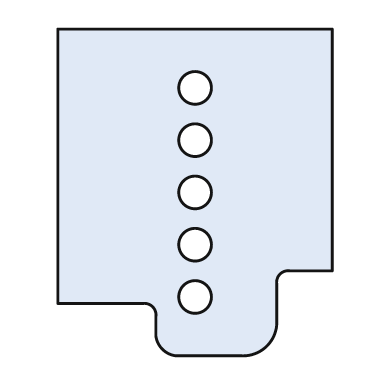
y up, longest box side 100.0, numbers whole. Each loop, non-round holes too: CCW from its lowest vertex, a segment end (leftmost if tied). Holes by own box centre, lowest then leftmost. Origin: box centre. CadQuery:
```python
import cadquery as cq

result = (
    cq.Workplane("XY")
    .moveTo(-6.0, -50.0)
    .lineTo(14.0, -50.0)
    .threePointArc((22.0, -47.0), (25.0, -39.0))
    .lineTo(25.0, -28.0)
    .threePointArc((26.0, -25.0), (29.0, -24.0))
    .lineTo(42.0, -24.0)
    .lineTo(42.0, 50.0)
    .lineTo(-42.0, 50.0)
    .lineTo(-42.0, -34.0)
    .lineTo(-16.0, -34.0)
    .threePointArc((-13.0, -35.0), (-12.0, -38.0))
    .lineTo(-12.0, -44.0)
    .threePointArc((-10.0, -48.0), (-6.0, -50.0))
    .close()
    .moveTo(0.0, -32.0)
    .circle(5.0)
    .moveTo(0.0, -16.0)
    .circle(5.0)
    .moveTo(0.0, 0.0)
    .circle(5.0)
    .moveTo(0.0, 16.0)
    .circle(5.0)
    .moveTo(0.0, 32.0)
    .circle(5.0)
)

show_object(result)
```